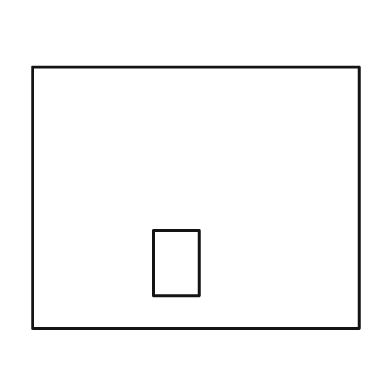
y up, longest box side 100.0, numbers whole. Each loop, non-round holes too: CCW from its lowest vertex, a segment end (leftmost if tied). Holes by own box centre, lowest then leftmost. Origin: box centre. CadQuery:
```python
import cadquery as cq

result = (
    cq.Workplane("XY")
    .moveTo(-50.0, -40.0)
    .lineTo(50.0, -40.0)
    .lineTo(50.0, 40.0)
    .lineTo(-50.0, 40.0)
    .close()
    .moveTo(-13.0, -30.0)
    .lineTo(1.0, -30.0)
    .lineTo(1.0, -10.0)
    .lineTo(-13.0, -10.0)
    .close()
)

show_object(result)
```